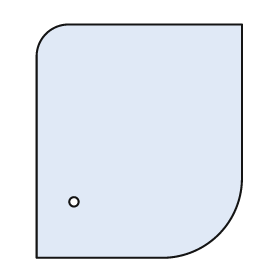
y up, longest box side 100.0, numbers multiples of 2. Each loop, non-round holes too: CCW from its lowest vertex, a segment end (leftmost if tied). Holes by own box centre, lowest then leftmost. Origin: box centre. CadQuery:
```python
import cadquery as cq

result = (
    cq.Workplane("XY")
    .moveTo(-44.0, -50.0)
    .lineTo(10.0, -50.0)
    .threePointArc((34.0, -40.0), (44.0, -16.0))
    .lineTo(44.0, 50.0)
    .lineTo(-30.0, 50.0)
    .threePointArc((-40.0, 46.0), (-44.0, 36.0))
    .close()
    .moveTo(-28.0, -26.0)
    .circle(2.0)
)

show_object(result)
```